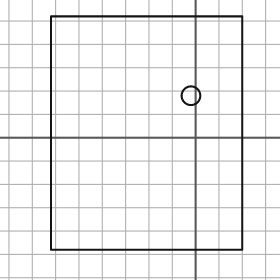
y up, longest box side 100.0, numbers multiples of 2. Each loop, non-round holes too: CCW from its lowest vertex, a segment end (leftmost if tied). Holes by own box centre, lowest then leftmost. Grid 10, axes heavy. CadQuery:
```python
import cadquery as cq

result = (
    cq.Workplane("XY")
    .moveTo(-62.0, -48.0)
    .lineTo(20.0, -48.0)
    .lineTo(20.0, 52.0)
    .lineTo(-62.0, 52.0)
    .close()
    .moveTo(-2.0, 18.0)
    .circle(4.0)
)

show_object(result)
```